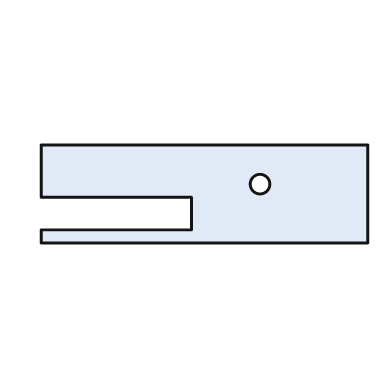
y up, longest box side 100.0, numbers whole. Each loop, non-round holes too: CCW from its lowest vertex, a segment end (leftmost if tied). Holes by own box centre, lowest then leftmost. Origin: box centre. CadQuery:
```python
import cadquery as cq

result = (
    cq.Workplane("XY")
    .moveTo(-50.0, -15.0)
    .lineTo(50.0, -15.0)
    .lineTo(50.0, 15.0)
    .lineTo(-50.0, 15.0)
    .lineTo(-50.0, -1.0)
    .lineTo(-4.0, -1.0)
    .lineTo(-4.0, -11.0)
    .lineTo(-50.0, -11.0)
    .close()
    .moveTo(17.0, 3.0)
    .circle(3.0)
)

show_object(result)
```